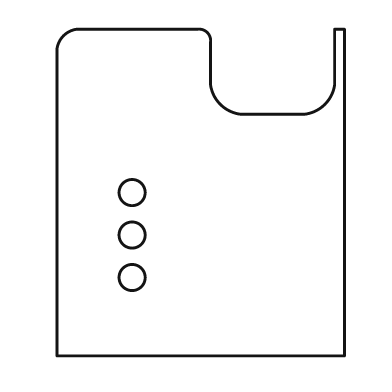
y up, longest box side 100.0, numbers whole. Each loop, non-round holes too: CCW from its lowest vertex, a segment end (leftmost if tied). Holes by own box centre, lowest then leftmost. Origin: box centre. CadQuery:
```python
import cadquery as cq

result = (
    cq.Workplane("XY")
    .moveTo(-44.0, -50.0)
    .lineTo(44.0, -50.0)
    .lineTo(44.0, 50.0)
    .lineTo(41.0, 50.0)
    .lineTo(41.0, 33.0)
    .threePointArc((38.0, 27.0), (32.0, 24.0))
    .lineTo(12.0, 24.0)
    .threePointArc((6.0, 27.0), (3.0, 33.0))
    .lineTo(3.0, 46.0)
    .threePointArc((2.0, 49.0), (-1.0, 50.0))
    .lineTo(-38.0, 50.0)
    .threePointArc((-42.0, 48.0), (-44.0, 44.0))
    .close()
    .moveTo(-21.0, -26.0)
    .circle(4.0)
    .moveTo(-21.0, -13.0)
    .circle(4.0)
    .moveTo(-21.0, 0.0)
    .circle(4.0)
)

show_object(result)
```